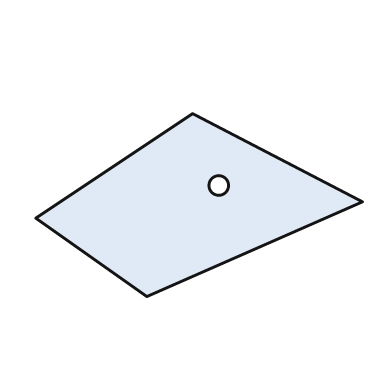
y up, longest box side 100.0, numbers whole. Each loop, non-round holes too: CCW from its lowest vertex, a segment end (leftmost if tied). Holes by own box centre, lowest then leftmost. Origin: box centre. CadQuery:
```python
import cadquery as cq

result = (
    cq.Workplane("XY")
    .moveTo(-16.0, -28.0)
    .lineTo(50.0, 1.0)
    .lineTo(-2.0, 28.0)
    .lineTo(-50.0, -4.0)
    .close()
    .moveTo(6.0, 6.0)
    .circle(3.0)
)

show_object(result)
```